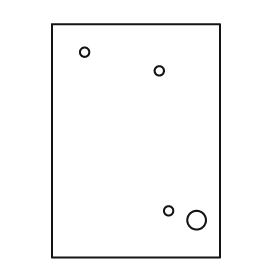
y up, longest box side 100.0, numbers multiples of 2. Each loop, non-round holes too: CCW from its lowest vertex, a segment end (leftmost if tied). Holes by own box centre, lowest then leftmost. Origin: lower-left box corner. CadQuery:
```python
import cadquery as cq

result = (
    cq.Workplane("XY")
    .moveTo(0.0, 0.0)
    .lineTo(72.0, 0.0)
    .lineTo(72.0, 100.0)
    .lineTo(0.0, 100.0)
    .close()
    .moveTo(62.0, 16.0)
    .circle(4.0)
    .moveTo(50.0, 20.0)
    .circle(2.0)
    .moveTo(46.0, 80.0)
    .circle(2.0)
    .moveTo(14.0, 88.0)
    .circle(2.0)
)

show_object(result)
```